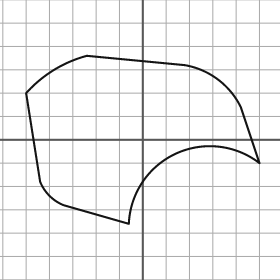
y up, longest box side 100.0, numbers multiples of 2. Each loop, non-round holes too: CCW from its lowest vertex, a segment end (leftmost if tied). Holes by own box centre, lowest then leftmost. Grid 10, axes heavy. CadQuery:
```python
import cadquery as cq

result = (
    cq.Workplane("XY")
    .moveTo(-6.0, -36.0)
    .threePointArc((14.0, -6.0), (50.0, -10.0))
    .lineTo(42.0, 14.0)
    .threePointArc((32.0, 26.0), (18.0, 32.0))
    .lineTo(-24.0, 36.0)
    .threePointArc((-38.0, 30.0), (-50.0, 20.0))
    .lineTo(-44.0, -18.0)
    .threePointArc((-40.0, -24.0), (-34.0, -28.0))
    .close()
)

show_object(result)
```